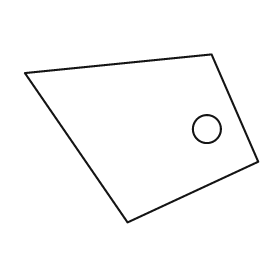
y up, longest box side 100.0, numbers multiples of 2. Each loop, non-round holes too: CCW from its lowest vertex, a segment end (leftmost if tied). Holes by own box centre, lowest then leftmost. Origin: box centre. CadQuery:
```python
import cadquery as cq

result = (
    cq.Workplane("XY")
    .moveTo(-6.0, -36.0)
    .lineTo(50.0, -10.0)
    .lineTo(30.0, 36.0)
    .lineTo(-50.0, 28.0)
    .close()
    .moveTo(28.0, 4.0)
    .circle(6.0)
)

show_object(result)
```